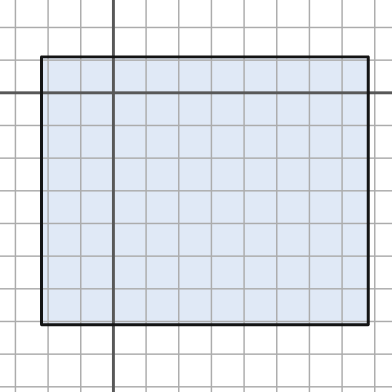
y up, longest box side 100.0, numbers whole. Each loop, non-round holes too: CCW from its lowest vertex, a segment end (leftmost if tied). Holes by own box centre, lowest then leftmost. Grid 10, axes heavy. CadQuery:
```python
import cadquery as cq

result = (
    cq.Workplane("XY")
    .moveTo(-22.0, -71.0)
    .lineTo(78.0, -71.0)
    .lineTo(78.0, 11.0)
    .lineTo(-22.0, 11.0)
    .close()
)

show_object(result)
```